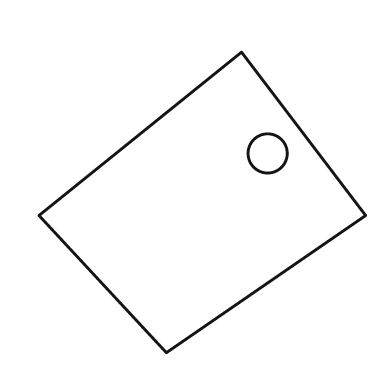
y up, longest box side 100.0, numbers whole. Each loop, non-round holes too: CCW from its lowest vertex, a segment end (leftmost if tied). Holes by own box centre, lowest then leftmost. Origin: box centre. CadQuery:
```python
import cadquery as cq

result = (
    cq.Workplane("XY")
    .moveTo(-11.0, -46.0)
    .lineTo(50.0, -4.0)
    .lineTo(12.0, 46.0)
    .lineTo(-50.0, -4.0)
    .close()
    .moveTo(20.0, 15.0)
    .circle(6.0)
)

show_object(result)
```